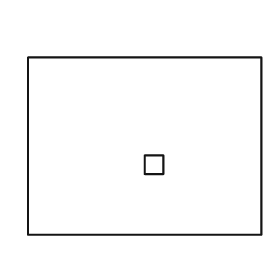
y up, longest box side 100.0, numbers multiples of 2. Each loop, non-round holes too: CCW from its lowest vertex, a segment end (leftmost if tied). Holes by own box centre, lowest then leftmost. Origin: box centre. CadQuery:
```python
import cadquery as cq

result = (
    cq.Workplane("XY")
    .moveTo(-50.0, -38.0)
    .lineTo(50.0, -38.0)
    .lineTo(50.0, 38.0)
    .lineTo(-50.0, 38.0)
    .close()
    .moveTo(0.0, -12.0)
    .lineTo(8.0, -12.0)
    .lineTo(8.0, -4.0)
    .lineTo(0.0, -4.0)
    .close()
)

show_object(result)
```